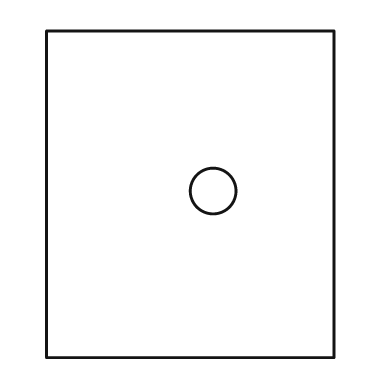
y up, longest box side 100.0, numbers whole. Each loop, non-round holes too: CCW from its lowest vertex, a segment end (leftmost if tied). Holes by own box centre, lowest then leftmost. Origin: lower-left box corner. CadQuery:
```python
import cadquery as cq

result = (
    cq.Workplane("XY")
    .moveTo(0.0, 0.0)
    .lineTo(88.0, 0.0)
    .lineTo(88.0, 100.0)
    .lineTo(0.0, 100.0)
    .close()
    .moveTo(51.0, 51.0)
    .circle(7.0)
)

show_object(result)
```